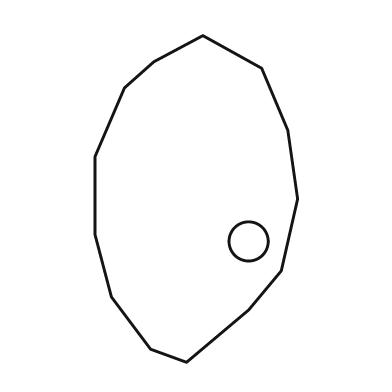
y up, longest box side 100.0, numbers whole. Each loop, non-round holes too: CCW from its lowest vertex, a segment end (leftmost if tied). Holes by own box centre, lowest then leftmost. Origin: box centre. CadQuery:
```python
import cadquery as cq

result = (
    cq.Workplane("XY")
    .moveTo(-3.0, -50.0)
    .lineTo(16.0, -34.0)
    .lineTo(26.0, -22.0)
    .lineTo(31.0, 0.0)
    .lineTo(28.0, 21.0)
    .lineTo(20.0, 40.0)
    .lineTo(2.0, 50.0)
    .lineTo(-13.0, 42.0)
    .lineTo(-22.0, 34.0)
    .lineTo(-31.0, 13.0)
    .lineTo(-31.0, -11.0)
    .lineTo(-26.0, -30.0)
    .lineTo(-14.0, -46.0)
    .close()
    .moveTo(16.0, -13.0)
    .circle(6.0)
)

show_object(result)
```